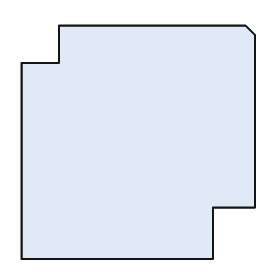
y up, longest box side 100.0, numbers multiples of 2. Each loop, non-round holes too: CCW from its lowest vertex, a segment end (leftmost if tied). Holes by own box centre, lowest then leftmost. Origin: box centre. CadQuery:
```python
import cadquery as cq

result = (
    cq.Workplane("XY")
    .moveTo(-50.0, -50.0)
    .lineTo(32.0, -50.0)
    .lineTo(32.0, -28.0)
    .lineTo(50.0, -28.0)
    .lineTo(50.0, 46.0)
    .lineTo(46.0, 50.0)
    .lineTo(-34.0, 50.0)
    .lineTo(-34.0, 34.0)
    .lineTo(-50.0, 34.0)
    .close()
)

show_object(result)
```